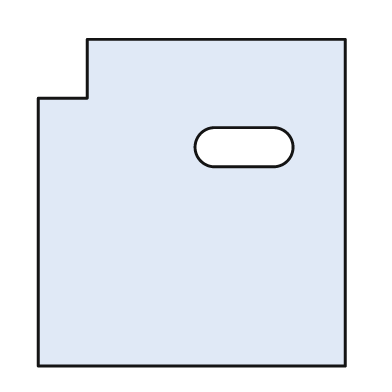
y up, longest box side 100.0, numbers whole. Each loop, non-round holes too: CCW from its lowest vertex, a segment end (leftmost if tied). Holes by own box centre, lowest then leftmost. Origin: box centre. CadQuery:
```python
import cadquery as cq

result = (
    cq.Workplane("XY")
    .moveTo(-47.0, -50.0)
    .lineTo(47.0, -50.0)
    .lineTo(47.0, 50.0)
    .lineTo(-32.0, 50.0)
    .lineTo(-32.0, 32.0)
    .lineTo(-47.0, 32.0)
    .close()
    .moveTo(7.0, 11.0)
    .lineTo(25.0, 11.0)
    .threePointArc((31.0, 17.0), (25.0, 23.0))
    .lineTo(7.0, 23.0)
    .threePointArc((1.0, 17.0), (7.0, 11.0))
    .close()
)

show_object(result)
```